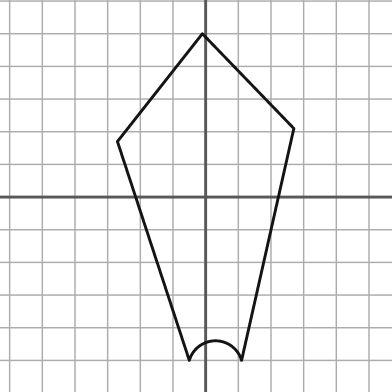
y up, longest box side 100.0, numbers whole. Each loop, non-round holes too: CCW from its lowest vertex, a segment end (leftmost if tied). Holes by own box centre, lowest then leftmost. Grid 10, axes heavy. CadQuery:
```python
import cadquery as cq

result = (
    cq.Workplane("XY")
    .moveTo(-5.0, -50.0)
    .threePointArc((3.0, -44.0), (11.0, -50.0))
    .lineTo(27.0, 21.0)
    .lineTo(-1.0, 50.0)
    .lineTo(-27.0, 17.0)
    .close()
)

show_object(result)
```